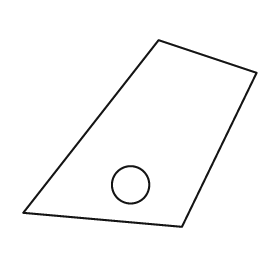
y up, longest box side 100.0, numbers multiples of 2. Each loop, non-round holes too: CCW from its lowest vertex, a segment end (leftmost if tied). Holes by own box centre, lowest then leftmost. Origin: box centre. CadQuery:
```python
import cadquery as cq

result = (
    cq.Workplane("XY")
    .moveTo(18.0, -40.0)
    .lineTo(50.0, 26.0)
    .lineTo(8.0, 40.0)
    .lineTo(-50.0, -34.0)
    .close()
    .moveTo(-4.0, -22.0)
    .circle(8.0)
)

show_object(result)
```